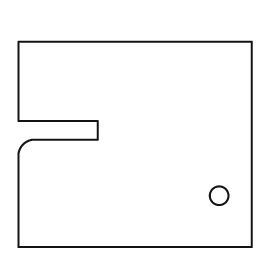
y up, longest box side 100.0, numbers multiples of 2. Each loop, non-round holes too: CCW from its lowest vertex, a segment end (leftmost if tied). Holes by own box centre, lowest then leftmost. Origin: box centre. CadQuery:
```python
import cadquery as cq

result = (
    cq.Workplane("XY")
    .moveTo(-50.0, -44.0)
    .lineTo(50.0, -44.0)
    .lineTo(50.0, 44.0)
    .lineTo(-50.0, 44.0)
    .lineTo(-50.0, 10.0)
    .lineTo(-16.0, 10.0)
    .lineTo(-16.0, 2.0)
    .lineTo(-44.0, 2.0)
    .threePointArc((-48.0, 0.0), (-50.0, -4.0))
    .close()
    .moveTo(36.0, -22.0)
    .circle(4.0)
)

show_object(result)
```